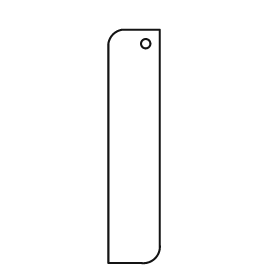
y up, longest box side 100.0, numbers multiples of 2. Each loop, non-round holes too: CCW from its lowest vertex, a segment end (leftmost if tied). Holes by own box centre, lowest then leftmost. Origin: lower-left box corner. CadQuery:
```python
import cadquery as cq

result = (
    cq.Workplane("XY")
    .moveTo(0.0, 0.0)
    .lineTo(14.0, 0.0)
    .threePointArc((20.0, 2.0), (22.0, 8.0))
    .lineTo(22.0, 100.0)
    .lineTo(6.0, 100.0)
    .threePointArc((2.0, 98.0), (0.0, 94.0))
    .close()
    .moveTo(16.0, 94.0)
    .circle(2.0)
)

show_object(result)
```